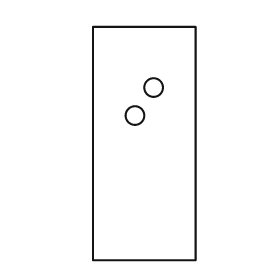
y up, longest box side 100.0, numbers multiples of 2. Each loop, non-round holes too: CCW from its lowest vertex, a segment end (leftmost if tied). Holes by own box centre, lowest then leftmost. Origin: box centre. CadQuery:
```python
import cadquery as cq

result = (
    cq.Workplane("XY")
    .moveTo(-22.0, -50.0)
    .lineTo(22.0, -50.0)
    .lineTo(22.0, 50.0)
    .lineTo(-22.0, 50.0)
    .close()
    .moveTo(-4.0, 12.0)
    .circle(4.0)
    .moveTo(4.0, 24.0)
    .circle(4.0)
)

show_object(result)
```